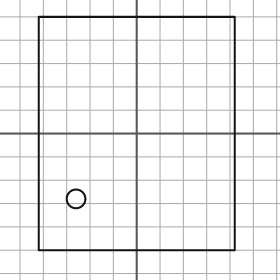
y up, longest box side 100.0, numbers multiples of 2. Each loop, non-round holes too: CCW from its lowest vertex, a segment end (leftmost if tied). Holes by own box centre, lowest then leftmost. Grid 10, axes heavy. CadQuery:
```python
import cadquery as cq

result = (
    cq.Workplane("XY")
    .moveTo(-42.0, -50.0)
    .lineTo(42.0, -50.0)
    .lineTo(42.0, 50.0)
    .lineTo(-42.0, 50.0)
    .close()
    .moveTo(-26.0, -28.0)
    .circle(4.0)
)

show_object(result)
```